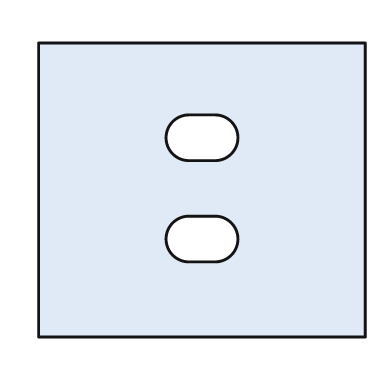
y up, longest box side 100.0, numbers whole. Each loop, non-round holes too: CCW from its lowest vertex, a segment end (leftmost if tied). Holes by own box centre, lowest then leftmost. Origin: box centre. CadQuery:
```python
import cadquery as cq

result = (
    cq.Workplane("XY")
    .moveTo(-50.0, -45.0)
    .lineTo(50.0, -45.0)
    .lineTo(50.0, 45.0)
    .lineTo(-50.0, 45.0)
    .close()
    .moveTo(-4.0, -22.0)
    .lineTo(4.0, -22.0)
    .threePointArc((11.0, -15.0), (4.0, -8.0))
    .lineTo(-4.0, -8.0)
    .threePointArc((-11.0, -15.0), (-4.0, -22.0))
    .close()
    .moveTo(-4.0, 9.0)
    .lineTo(4.0, 9.0)
    .threePointArc((11.0, 16.0), (4.0, 23.0))
    .lineTo(-4.0, 23.0)
    .threePointArc((-11.0, 16.0), (-4.0, 9.0))
    .close()
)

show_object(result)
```